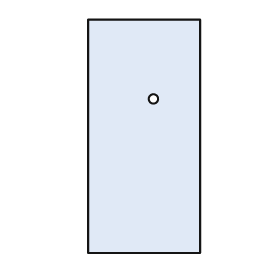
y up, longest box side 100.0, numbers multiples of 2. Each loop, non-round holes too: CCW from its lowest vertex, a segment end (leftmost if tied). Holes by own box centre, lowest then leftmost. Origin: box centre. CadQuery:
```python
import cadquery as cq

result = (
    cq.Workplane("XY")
    .moveTo(-24.0, -50.0)
    .lineTo(24.0, -50.0)
    .lineTo(24.0, 50.0)
    .lineTo(-24.0, 50.0)
    .close()
    .moveTo(4.0, 16.0)
    .circle(2.0)
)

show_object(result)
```